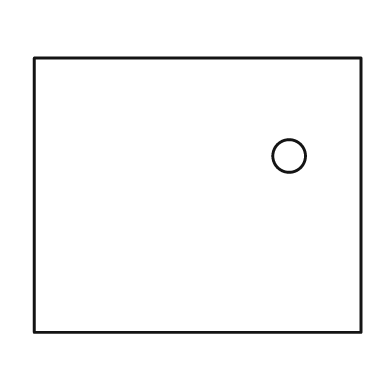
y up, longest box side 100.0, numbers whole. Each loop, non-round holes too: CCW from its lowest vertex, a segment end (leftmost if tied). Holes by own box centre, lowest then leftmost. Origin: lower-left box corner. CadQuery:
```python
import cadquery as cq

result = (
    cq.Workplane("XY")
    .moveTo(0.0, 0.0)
    .lineTo(100.0, 0.0)
    .lineTo(100.0, 84.0)
    .lineTo(0.0, 84.0)
    .close()
    .moveTo(78.0, 54.0)
    .circle(5.0)
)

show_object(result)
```